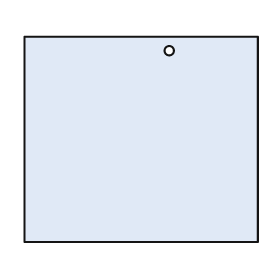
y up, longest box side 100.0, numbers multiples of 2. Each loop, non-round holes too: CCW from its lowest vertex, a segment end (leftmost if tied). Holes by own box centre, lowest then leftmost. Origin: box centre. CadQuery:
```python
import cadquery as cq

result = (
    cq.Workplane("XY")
    .moveTo(-50.0, -44.0)
    .lineTo(50.0, -44.0)
    .lineTo(50.0, 44.0)
    .lineTo(-50.0, 44.0)
    .close()
    .moveTo(12.0, 38.0)
    .circle(2.0)
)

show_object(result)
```